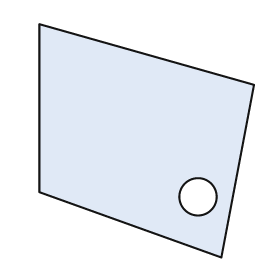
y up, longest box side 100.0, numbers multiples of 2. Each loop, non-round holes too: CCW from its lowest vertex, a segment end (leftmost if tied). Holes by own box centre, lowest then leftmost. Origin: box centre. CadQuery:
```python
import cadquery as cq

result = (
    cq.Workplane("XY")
    .moveTo(32.0, -50.0)
    .lineTo(46.0, 24.0)
    .lineTo(-46.0, 50.0)
    .lineTo(-46.0, -22.0)
    .close()
    .moveTo(22.0, -24.0)
    .circle(8.0)
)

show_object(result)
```